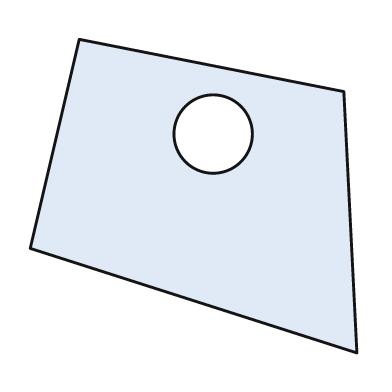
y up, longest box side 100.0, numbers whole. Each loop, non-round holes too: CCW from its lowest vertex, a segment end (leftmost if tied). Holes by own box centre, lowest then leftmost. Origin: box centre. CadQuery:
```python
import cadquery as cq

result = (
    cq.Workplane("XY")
    .moveTo(50.0, -48.0)
    .lineTo(46.0, 32.0)
    .lineTo(-35.0, 48.0)
    .lineTo(-50.0, -16.0)
    .close()
    .moveTo(6.0, 19.0)
    .circle(12.0)
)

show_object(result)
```